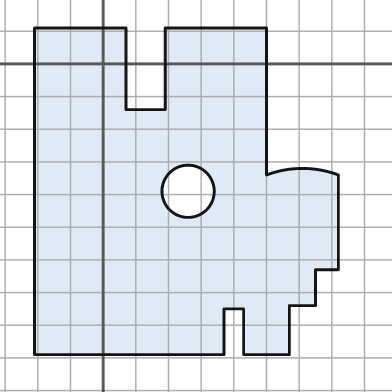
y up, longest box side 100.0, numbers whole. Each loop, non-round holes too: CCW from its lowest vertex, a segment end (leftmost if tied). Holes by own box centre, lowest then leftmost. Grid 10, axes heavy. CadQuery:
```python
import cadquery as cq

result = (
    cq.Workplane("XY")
    .moveTo(-21.0, -89.0)
    .lineTo(37.0, -89.0)
    .lineTo(37.0, -75.0)
    .lineTo(43.0, -75.0)
    .lineTo(43.0, -89.0)
    .lineTo(57.0, -89.0)
    .lineTo(57.0, -74.0)
    .lineTo(65.0, -74.0)
    .lineTo(65.0, -63.0)
    .lineTo(72.0, -63.0)
    .lineTo(72.0, -34.0)
    .threePointArc((61.0, -32.0), (50.0, -34.0))
    .lineTo(50.0, 11.0)
    .lineTo(19.0, 11.0)
    .lineTo(19.0, -14.0)
    .lineTo(7.0, -14.0)
    .lineTo(7.0, 11.0)
    .lineTo(-21.0, 11.0)
    .close()
    .moveTo(26.0, -39.0)
    .circle(8.0)
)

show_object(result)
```